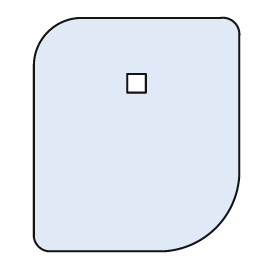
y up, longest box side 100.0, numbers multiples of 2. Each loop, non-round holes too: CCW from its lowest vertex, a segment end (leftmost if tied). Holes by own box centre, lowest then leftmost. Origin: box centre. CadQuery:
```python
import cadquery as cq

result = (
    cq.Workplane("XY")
    .moveTo(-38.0, -50.0)
    .lineTo(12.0, -50.0)
    .threePointArc((34.0, -40.0), (44.0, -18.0))
    .lineTo(44.0, 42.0)
    .threePointArc((42.0, 48.0), (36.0, 50.0))
    .lineTo(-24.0, 50.0)
    .threePointArc((-38.0, 44.0), (-44.0, 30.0))
    .lineTo(-44.0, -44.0)
    .threePointArc((-42.0, -48.0), (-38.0, -50.0))
    .close()
    .moveTo(-4.0, 18.0)
    .lineTo(4.0, 18.0)
    .lineTo(4.0, 26.0)
    .lineTo(-4.0, 26.0)
    .close()
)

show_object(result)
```